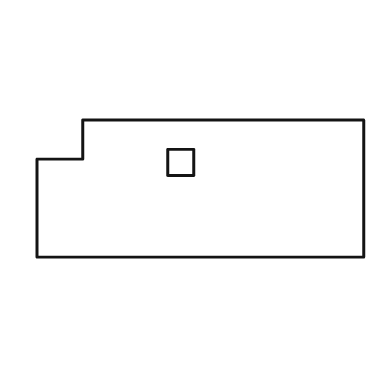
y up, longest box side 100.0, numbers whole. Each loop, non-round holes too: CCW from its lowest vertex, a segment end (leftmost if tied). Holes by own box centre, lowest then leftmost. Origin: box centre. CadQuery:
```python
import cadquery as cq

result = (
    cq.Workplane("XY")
    .moveTo(-50.0, -21.0)
    .lineTo(50.0, -21.0)
    .lineTo(50.0, 21.0)
    .lineTo(-36.0, 21.0)
    .lineTo(-36.0, 9.0)
    .lineTo(-50.0, 9.0)
    .close()
    .moveTo(-10.0, 4.0)
    .lineTo(-2.0, 4.0)
    .lineTo(-2.0, 12.0)
    .lineTo(-10.0, 12.0)
    .close()
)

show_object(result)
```